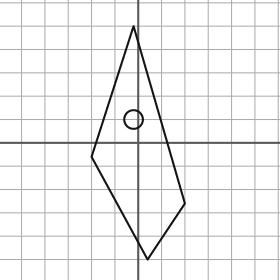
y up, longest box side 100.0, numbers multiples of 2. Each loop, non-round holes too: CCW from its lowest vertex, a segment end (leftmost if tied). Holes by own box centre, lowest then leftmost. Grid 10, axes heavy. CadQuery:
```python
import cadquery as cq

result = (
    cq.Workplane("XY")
    .moveTo(4.0, -50.0)
    .lineTo(20.0, -26.0)
    .lineTo(-2.0, 50.0)
    .lineTo(-20.0, -6.0)
    .close()
    .moveTo(-2.0, 10.0)
    .circle(4.0)
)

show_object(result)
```